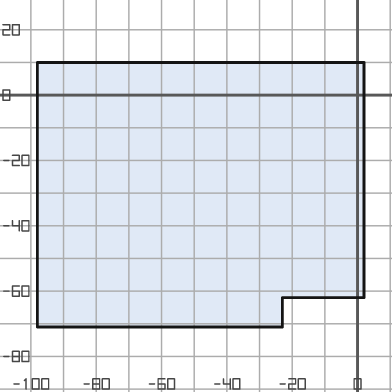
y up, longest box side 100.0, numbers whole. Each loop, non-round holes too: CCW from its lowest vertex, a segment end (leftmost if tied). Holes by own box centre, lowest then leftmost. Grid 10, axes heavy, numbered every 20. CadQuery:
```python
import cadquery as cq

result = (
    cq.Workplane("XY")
    .moveTo(-98.0, -71.0)
    .lineTo(-23.0, -71.0)
    .lineTo(-23.0, -62.0)
    .lineTo(2.0, -62.0)
    .lineTo(2.0, 10.0)
    .lineTo(-98.0, 10.0)
    .close()
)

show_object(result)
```